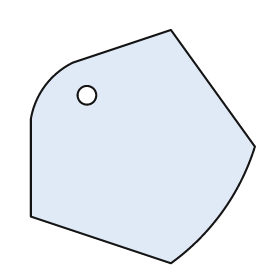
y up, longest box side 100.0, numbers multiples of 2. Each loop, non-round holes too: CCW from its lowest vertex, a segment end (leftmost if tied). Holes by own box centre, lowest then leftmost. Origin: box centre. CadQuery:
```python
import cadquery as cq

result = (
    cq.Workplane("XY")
    .moveTo(12.0, -50.0)
    .threePointArc((34.0, -28.0), (48.0, 0.0))
    .lineTo(12.0, 50.0)
    .lineTo(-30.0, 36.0)
    .threePointArc((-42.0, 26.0), (-48.0, 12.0))
    .lineTo(-48.0, -30.0)
    .close()
    .moveTo(-24.0, 22.0)
    .circle(4.0)
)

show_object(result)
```